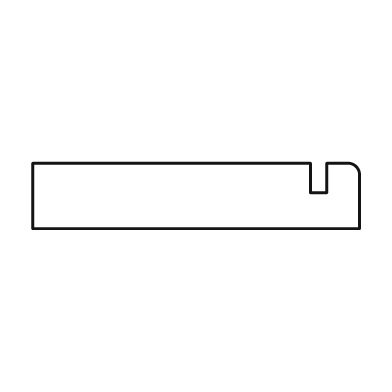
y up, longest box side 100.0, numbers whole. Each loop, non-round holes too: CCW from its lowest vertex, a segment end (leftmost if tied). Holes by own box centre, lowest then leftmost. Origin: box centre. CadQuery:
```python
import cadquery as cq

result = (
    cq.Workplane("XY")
    .moveTo(-50.0, -10.0)
    .lineTo(50.0, -10.0)
    .lineTo(50.0, 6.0)
    .threePointArc((49.0, 9.0), (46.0, 10.0))
    .lineTo(40.0, 10.0)
    .lineTo(40.0, 1.0)
    .lineTo(35.0, 1.0)
    .lineTo(35.0, 10.0)
    .lineTo(-50.0, 10.0)
    .close()
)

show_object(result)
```